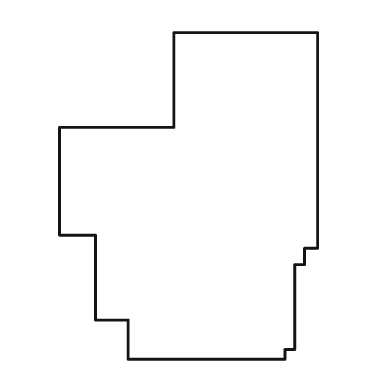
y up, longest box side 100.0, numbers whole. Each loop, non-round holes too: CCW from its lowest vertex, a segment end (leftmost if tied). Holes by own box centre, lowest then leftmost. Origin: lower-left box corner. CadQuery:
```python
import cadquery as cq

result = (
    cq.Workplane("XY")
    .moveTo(21.0, 0.0)
    .lineTo(69.0, 0.0)
    .lineTo(69.0, 3.0)
    .lineTo(72.0, 3.0)
    .lineTo(72.0, 29.0)
    .lineTo(75.0, 29.0)
    .lineTo(75.0, 34.0)
    .lineTo(79.0, 34.0)
    .lineTo(79.0, 100.0)
    .lineTo(35.0, 100.0)
    .lineTo(35.0, 71.0)
    .lineTo(0.0, 71.0)
    .lineTo(0.0, 38.0)
    .lineTo(11.0, 38.0)
    .lineTo(11.0, 12.0)
    .lineTo(21.0, 12.0)
    .close()
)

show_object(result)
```